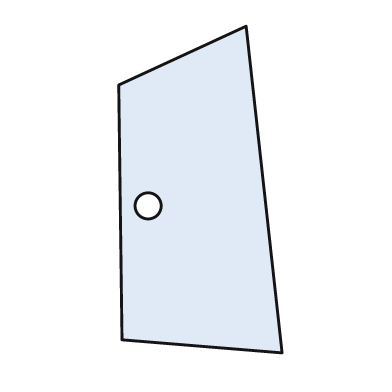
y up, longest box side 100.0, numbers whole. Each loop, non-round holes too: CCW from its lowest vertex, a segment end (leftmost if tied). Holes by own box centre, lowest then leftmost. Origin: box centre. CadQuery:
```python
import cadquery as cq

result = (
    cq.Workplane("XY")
    .moveTo(25.0, -50.0)
    .lineTo(14.0, 50.0)
    .lineTo(-25.0, 32.0)
    .lineTo(-24.0, -46.0)
    .close()
    .moveTo(-16.0, -5.0)
    .circle(4.0)
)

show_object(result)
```